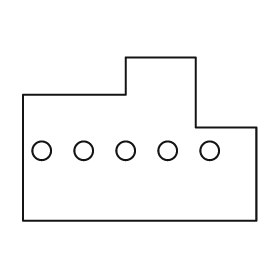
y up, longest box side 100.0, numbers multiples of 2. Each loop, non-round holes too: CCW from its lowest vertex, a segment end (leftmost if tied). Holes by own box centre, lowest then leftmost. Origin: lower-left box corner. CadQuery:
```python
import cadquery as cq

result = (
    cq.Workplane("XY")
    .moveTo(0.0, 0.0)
    .lineTo(100.0, 0.0)
    .lineTo(100.0, 40.0)
    .lineTo(74.0, 40.0)
    .lineTo(74.0, 70.0)
    .lineTo(44.0, 70.0)
    .lineTo(44.0, 54.0)
    .lineTo(0.0, 54.0)
    .close()
    .moveTo(8.0, 30.0)
    .circle(4.0)
    .moveTo(26.0, 30.0)
    .circle(4.0)
    .moveTo(44.0, 30.0)
    .circle(4.0)
    .moveTo(62.0, 30.0)
    .circle(4.0)
    .moveTo(80.0, 30.0)
    .circle(4.0)
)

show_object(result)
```